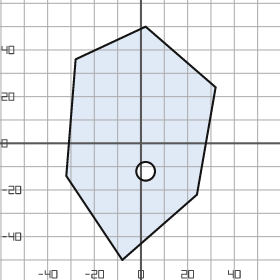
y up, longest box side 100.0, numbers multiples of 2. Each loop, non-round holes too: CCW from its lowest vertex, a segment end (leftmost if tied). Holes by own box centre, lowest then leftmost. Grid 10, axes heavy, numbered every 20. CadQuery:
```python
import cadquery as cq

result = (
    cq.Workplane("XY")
    .moveTo(-8.0, -50.0)
    .lineTo(24.0, -22.0)
    .lineTo(32.0, 24.0)
    .lineTo(2.0, 50.0)
    .lineTo(-28.0, 36.0)
    .lineTo(-32.0, -14.0)
    .close()
    .moveTo(2.0, -12.0)
    .circle(4.0)
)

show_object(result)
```